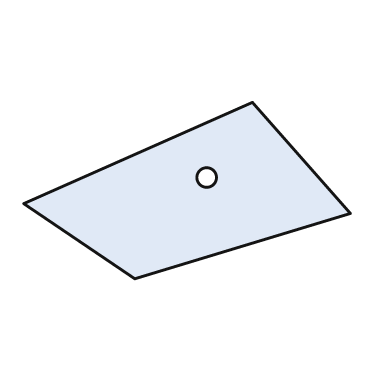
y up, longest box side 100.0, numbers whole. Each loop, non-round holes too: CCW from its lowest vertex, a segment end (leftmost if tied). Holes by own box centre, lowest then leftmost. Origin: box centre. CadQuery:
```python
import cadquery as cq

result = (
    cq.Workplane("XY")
    .moveTo(-16.0, -27.0)
    .lineTo(50.0, -7.0)
    .lineTo(20.0, 27.0)
    .lineTo(-50.0, -4.0)
    .close()
    .moveTo(6.0, 4.0)
    .circle(3.0)
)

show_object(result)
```